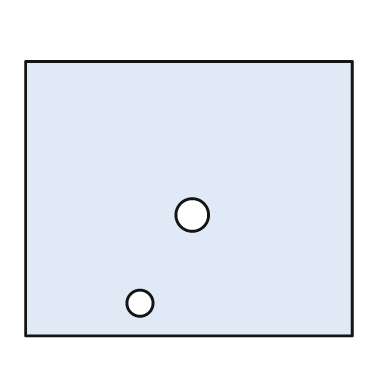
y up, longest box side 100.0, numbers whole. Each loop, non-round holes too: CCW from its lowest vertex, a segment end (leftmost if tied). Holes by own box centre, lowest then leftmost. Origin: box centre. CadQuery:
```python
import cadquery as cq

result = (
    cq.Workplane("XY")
    .moveTo(-50.0, -42.0)
    .lineTo(50.0, -42.0)
    .lineTo(50.0, 42.0)
    .lineTo(-50.0, 42.0)
    .close()
    .moveTo(-15.0, -32.0)
    .circle(4.0)
    .moveTo(1.0, -5.0)
    .circle(5.0)
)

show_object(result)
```